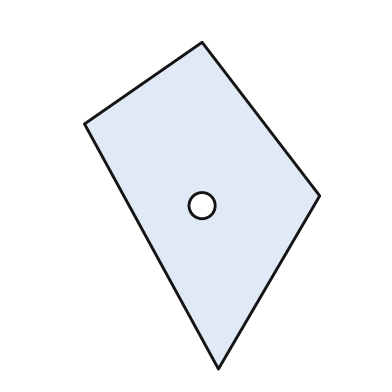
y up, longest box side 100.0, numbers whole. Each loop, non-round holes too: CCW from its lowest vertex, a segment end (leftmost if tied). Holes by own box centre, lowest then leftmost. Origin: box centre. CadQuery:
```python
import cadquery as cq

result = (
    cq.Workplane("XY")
    .moveTo(5.0, -50.0)
    .lineTo(36.0, 3.0)
    .lineTo(0.0, 50.0)
    .lineTo(-36.0, 25.0)
    .close()
    .moveTo(0.0, 0.0)
    .circle(4.0)
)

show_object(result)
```